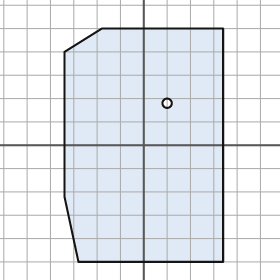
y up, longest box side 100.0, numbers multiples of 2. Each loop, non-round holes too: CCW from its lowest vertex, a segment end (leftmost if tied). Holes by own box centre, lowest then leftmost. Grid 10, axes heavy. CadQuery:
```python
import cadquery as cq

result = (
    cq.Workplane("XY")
    .moveTo(-28.0, -50.0)
    .lineTo(34.0, -50.0)
    .lineTo(34.0, 50.0)
    .lineTo(-18.0, 50.0)
    .lineTo(-34.0, 40.0)
    .lineTo(-34.0, -22.0)
    .close()
    .moveTo(10.0, 18.0)
    .circle(2.0)
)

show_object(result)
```